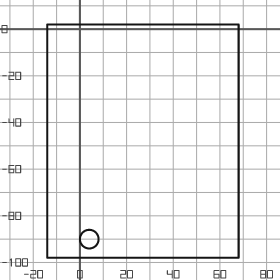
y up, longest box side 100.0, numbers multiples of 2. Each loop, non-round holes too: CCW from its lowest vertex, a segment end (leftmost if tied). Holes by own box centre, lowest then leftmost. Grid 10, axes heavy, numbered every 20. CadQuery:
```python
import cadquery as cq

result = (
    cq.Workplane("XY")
    .moveTo(-14.0, -98.0)
    .lineTo(68.0, -98.0)
    .lineTo(68.0, 2.0)
    .lineTo(-14.0, 2.0)
    .close()
    .moveTo(4.0, -90.0)
    .circle(4.0)
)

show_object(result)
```